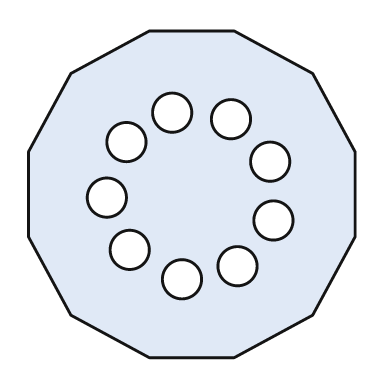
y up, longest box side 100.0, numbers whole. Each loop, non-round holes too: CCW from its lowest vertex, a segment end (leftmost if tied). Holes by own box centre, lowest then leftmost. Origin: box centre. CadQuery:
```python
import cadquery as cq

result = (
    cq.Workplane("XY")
    .moveTo(-13.0, -50.0)
    .lineTo(13.0, -50.0)
    .lineTo(37.0, -37.0)
    .lineTo(50.0, -13.0)
    .lineTo(50.0, 13.0)
    .lineTo(37.0, 37.0)
    .lineTo(13.0, 50.0)
    .lineTo(-13.0, 50.0)
    .lineTo(-37.0, 37.0)
    .lineTo(-50.0, 13.0)
    .lineTo(-50.0, -13.0)
    .lineTo(-37.0, -37.0)
    .close()
    .moveTo(-3.0, -26.0)
    .circle(6.0)
    .moveTo(14.0, -22.0)
    .circle(6.0)
    .moveTo(-19.0, -17.0)
    .circle(6.0)
    .moveTo(25.0, -8.0)
    .circle(6.0)
    .moveTo(-26.0, -1.0)
    .circle(6.0)
    .moveTo(24.0, 10.0)
    .circle(6.0)
    .moveTo(-20.0, 16.0)
    .circle(6.0)
    .moveTo(12.0, 23.0)
    .circle(6.0)
    .moveTo(-6.0, 25.0)
    .circle(6.0)
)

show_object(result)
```